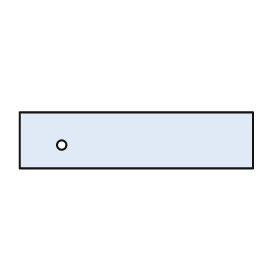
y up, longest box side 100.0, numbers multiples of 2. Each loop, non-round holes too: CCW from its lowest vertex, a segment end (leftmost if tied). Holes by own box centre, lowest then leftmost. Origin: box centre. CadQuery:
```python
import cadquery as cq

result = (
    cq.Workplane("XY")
    .moveTo(-50.0, -12.0)
    .lineTo(50.0, -12.0)
    .lineTo(50.0, 12.0)
    .lineTo(-50.0, 12.0)
    .close()
    .moveTo(-32.0, -2.0)
    .circle(2.0)
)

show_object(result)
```